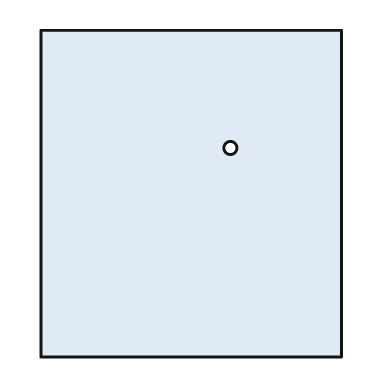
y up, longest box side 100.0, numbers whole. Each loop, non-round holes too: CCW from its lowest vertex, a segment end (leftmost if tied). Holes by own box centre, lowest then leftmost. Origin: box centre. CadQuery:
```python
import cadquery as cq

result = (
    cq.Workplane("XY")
    .moveTo(-46.0, -50.0)
    .lineTo(46.0, -50.0)
    .lineTo(46.0, 50.0)
    .lineTo(-46.0, 50.0)
    .close()
    .moveTo(12.0, 14.0)
    .circle(2.0)
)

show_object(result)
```